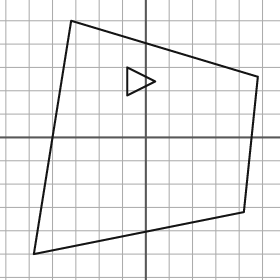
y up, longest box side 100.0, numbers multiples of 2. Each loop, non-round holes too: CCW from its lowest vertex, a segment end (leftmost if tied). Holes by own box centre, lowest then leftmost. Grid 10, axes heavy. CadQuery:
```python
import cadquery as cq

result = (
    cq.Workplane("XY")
    .moveTo(-48.0, -50.0)
    .lineTo(42.0, -32.0)
    .lineTo(48.0, 26.0)
    .lineTo(-32.0, 50.0)
    .close()
    .moveTo(-8.0, 18.0)
    .lineTo(4.0, 24.0)
    .lineTo(-8.0, 30.0)
    .close()
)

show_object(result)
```